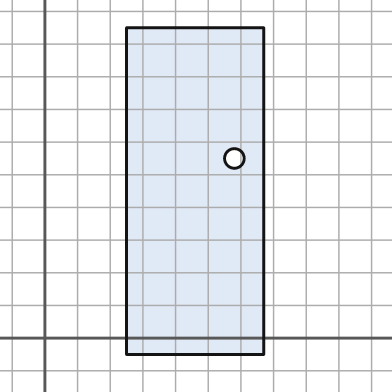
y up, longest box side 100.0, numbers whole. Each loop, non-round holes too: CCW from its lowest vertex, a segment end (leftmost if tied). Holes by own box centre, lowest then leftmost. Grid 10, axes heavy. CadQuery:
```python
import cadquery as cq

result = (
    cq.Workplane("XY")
    .moveTo(25.0, -5.0)
    .lineTo(67.0, -5.0)
    .lineTo(67.0, 95.0)
    .lineTo(25.0, 95.0)
    .close()
    .moveTo(58.0, 55.0)
    .circle(3.0)
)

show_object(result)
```